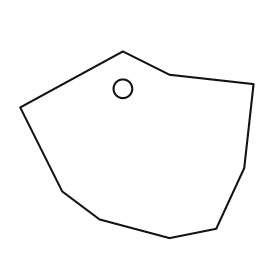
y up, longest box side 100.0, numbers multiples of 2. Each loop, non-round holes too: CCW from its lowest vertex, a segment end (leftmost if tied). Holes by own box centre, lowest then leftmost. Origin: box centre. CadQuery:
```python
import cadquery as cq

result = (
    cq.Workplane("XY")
    .moveTo(14.0, -40.0)
    .lineTo(34.0, -36.0)
    .lineTo(46.0, -10.0)
    .lineTo(50.0, 26.0)
    .lineTo(14.0, 30.0)
    .lineTo(-6.0, 40.0)
    .lineTo(-50.0, 16.0)
    .lineTo(-32.0, -20.0)
    .lineTo(-16.0, -32.0)
    .close()
    .moveTo(-6.0, 24.0)
    .circle(4.0)
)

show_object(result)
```